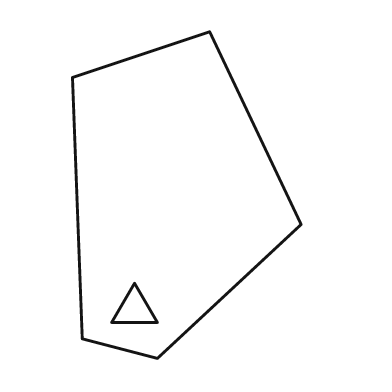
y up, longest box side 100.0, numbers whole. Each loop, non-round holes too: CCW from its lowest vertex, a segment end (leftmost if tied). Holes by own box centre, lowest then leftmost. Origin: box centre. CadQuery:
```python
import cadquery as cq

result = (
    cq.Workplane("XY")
    .moveTo(-9.0, -50.0)
    .lineTo(35.0, -9.0)
    .lineTo(7.0, 50.0)
    .lineTo(-35.0, 36.0)
    .lineTo(-32.0, -44.0)
    .close()
    .moveTo(-23.0, -39.0)
    .lineTo(-9.0, -39.0)
    .lineTo(-16.0, -27.0)
    .close()
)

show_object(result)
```